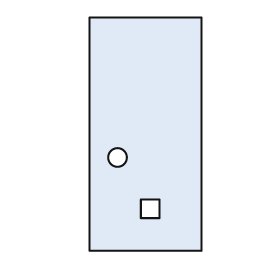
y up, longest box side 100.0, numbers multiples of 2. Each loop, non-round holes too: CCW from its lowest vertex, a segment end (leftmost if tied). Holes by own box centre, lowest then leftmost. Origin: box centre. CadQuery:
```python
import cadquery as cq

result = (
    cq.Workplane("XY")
    .moveTo(-24.0, -50.0)
    .lineTo(24.0, -50.0)
    .lineTo(24.0, 50.0)
    .lineTo(-24.0, 50.0)
    .close()
    .moveTo(-2.0, -36.0)
    .lineTo(6.0, -36.0)
    .lineTo(6.0, -28.0)
    .lineTo(-2.0, -28.0)
    .close()
    .moveTo(-12.0, -10.0)
    .circle(4.0)
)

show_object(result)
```